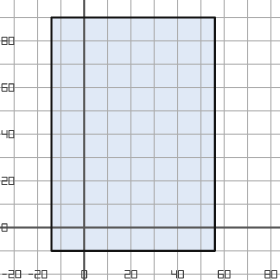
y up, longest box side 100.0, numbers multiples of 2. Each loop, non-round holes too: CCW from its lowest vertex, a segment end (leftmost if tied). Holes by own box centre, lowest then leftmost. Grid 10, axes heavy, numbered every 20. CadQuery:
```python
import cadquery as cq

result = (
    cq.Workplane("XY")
    .moveTo(-14.0, -10.0)
    .lineTo(56.0, -10.0)
    .lineTo(56.0, 90.0)
    .lineTo(-14.0, 90.0)
    .close()
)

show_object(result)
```